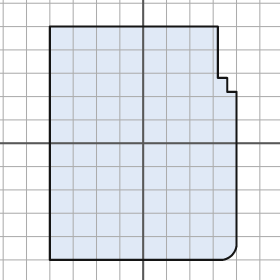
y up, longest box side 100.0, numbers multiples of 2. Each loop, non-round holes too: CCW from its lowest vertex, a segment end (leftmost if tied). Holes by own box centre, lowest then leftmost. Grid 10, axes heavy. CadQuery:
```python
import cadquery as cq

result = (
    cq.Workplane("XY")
    .moveTo(-40.0, -50.0)
    .lineTo(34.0, -50.0)
    .threePointArc((38.0, -48.0), (40.0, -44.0))
    .lineTo(40.0, 22.0)
    .lineTo(36.0, 22.0)
    .lineTo(36.0, 28.0)
    .lineTo(32.0, 28.0)
    .lineTo(32.0, 50.0)
    .lineTo(-40.0, 50.0)
    .close()
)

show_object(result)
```